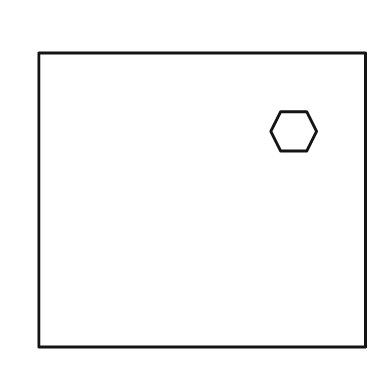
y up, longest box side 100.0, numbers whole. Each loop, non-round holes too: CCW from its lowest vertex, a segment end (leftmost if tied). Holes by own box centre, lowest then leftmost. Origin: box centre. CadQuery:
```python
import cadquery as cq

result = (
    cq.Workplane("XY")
    .moveTo(-50.0, -45.0)
    .lineTo(50.0, -45.0)
    .lineTo(50.0, 45.0)
    .lineTo(-50.0, 45.0)
    .close()
    .moveTo(24.0, 15.0)
    .lineTo(32.0, 15.0)
    .lineTo(35.0, 21.0)
    .lineTo(32.0, 27.0)
    .lineTo(24.0, 27.0)
    .lineTo(21.0, 21.0)
    .close()
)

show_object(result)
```